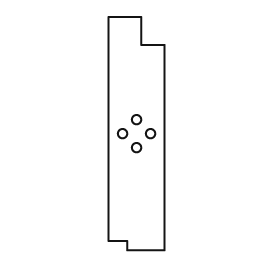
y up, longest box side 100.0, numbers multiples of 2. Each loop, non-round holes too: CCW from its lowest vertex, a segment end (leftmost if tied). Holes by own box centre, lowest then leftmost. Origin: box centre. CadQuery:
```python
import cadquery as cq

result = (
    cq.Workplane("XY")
    .moveTo(-4.0, -50.0)
    .lineTo(12.0, -50.0)
    .lineTo(12.0, 38.0)
    .lineTo(2.0, 38.0)
    .lineTo(2.0, 50.0)
    .lineTo(-12.0, 50.0)
    .lineTo(-12.0, -46.0)
    .lineTo(-4.0, -46.0)
    .close()
    .moveTo(0.0, -6.0)
    .circle(2.0)
    .moveTo(-6.0, 0.0)
    .circle(2.0)
    .moveTo(6.0, 0.0)
    .circle(2.0)
    .moveTo(0.0, 6.0)
    .circle(2.0)
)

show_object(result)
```